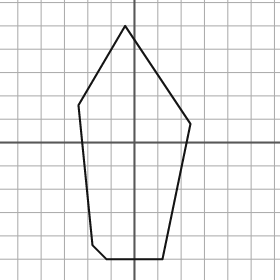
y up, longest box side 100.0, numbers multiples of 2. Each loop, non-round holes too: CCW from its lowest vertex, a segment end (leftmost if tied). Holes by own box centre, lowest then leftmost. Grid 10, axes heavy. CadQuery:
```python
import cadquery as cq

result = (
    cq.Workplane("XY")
    .moveTo(-12.0, -50.0)
    .lineTo(12.0, -50.0)
    .lineTo(24.0, 8.0)
    .lineTo(-4.0, 50.0)
    .lineTo(-24.0, 16.0)
    .lineTo(-18.0, -44.0)
    .close()
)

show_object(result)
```